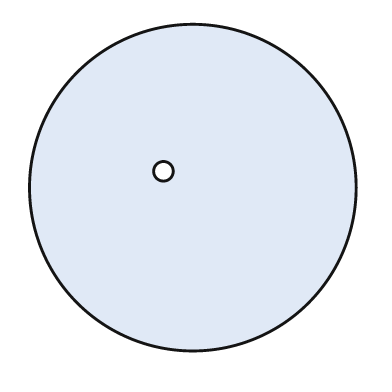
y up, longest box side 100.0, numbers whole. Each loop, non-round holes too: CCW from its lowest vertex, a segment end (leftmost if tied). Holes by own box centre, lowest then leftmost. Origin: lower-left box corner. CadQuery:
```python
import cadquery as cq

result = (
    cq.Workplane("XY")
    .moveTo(50.0, 50.0)
    .circle(50.0)
    .moveTo(41.0, 55.0)
    .circle(3.0)
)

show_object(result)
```